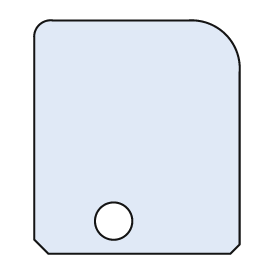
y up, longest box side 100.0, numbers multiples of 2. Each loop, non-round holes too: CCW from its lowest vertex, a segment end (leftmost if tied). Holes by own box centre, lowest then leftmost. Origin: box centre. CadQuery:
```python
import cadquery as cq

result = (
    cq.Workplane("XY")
    .moveTo(-38.0, -50.0)
    .lineTo(40.0, -50.0)
    .lineTo(44.0, -46.0)
    .lineTo(44.0, 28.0)
    .threePointArc((38.0, 44.0), (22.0, 50.0))
    .lineTo(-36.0, 50.0)
    .threePointArc((-42.0, 48.0), (-44.0, 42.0))
    .lineTo(-44.0, -44.0)
    .close()
    .moveTo(-10.0, -36.0)
    .circle(8.0)
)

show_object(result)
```